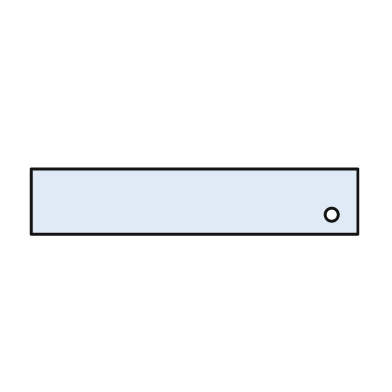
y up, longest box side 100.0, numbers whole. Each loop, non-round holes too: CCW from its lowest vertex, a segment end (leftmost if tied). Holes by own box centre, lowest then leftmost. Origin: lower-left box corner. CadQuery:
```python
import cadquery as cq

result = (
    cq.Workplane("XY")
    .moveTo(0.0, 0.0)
    .lineTo(100.0, 0.0)
    .lineTo(100.0, 20.0)
    .lineTo(0.0, 20.0)
    .close()
    .moveTo(92.0, 6.0)
    .circle(2.0)
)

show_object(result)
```